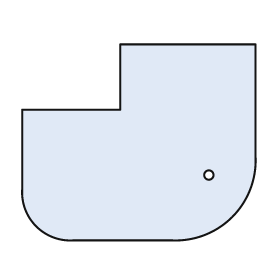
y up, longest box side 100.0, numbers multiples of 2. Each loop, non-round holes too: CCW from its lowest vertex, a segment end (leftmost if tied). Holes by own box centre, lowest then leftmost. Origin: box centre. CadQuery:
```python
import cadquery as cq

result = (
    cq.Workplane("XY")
    .moveTo(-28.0, -42.0)
    .lineTo(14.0, -42.0)
    .threePointArc((40.0, -32.0), (50.0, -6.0))
    .lineTo(50.0, 42.0)
    .lineTo(-8.0, 42.0)
    .lineTo(-8.0, 14.0)
    .lineTo(-50.0, 14.0)
    .lineTo(-50.0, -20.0)
    .threePointArc((-44.0, -36.0), (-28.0, -42.0))
    .close()
    .moveTo(30.0, -14.0)
    .circle(2.0)
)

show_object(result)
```